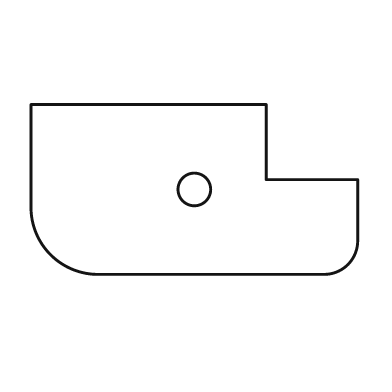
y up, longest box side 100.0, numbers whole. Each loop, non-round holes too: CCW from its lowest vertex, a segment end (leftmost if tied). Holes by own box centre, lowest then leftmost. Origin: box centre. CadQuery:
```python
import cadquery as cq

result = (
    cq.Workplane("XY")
    .moveTo(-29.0, -26.0)
    .lineTo(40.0, -26.0)
    .threePointArc((47.0, -23.0), (50.0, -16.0))
    .lineTo(50.0, 3.0)
    .lineTo(22.0, 3.0)
    .lineTo(22.0, 26.0)
    .lineTo(-50.0, 26.0)
    .lineTo(-50.0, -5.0)
    .threePointArc((-44.0, -20.0), (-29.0, -26.0))
    .close()
    .moveTo(0.0, 0.0)
    .circle(5.0)
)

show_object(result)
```